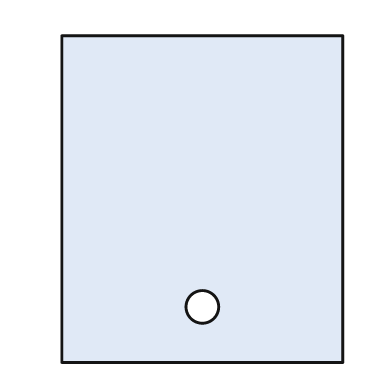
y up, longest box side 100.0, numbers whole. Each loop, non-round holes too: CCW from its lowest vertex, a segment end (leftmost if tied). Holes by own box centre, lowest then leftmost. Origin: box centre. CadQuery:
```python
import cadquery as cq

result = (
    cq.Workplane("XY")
    .moveTo(-43.0, -50.0)
    .lineTo(43.0, -50.0)
    .lineTo(43.0, 50.0)
    .lineTo(-43.0, 50.0)
    .close()
    .moveTo(0.0, -33.0)
    .circle(5.0)
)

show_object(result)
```